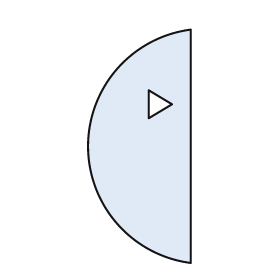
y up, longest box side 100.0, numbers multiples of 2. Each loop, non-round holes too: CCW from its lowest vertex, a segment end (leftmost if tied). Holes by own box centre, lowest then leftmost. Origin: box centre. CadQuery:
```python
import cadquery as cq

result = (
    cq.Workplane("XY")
    .moveTo(22.0, -50.0)
    .lineTo(22.0, 50.0)
    .threePointArc((-22.0, 0.0), (22.0, -50.0))
    .close()
    .moveTo(4.0, 12.0)
    .lineTo(14.0, 18.0)
    .lineTo(4.0, 24.0)
    .close()
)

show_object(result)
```